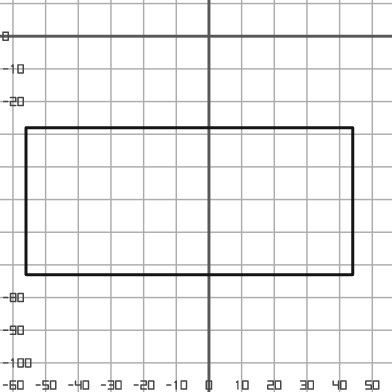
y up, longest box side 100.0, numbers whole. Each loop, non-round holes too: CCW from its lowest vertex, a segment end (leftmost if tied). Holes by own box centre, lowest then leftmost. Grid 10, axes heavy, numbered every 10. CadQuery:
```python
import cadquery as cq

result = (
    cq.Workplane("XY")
    .moveTo(-56.0, -73.0)
    .lineTo(44.0, -73.0)
    .lineTo(44.0, -28.0)
    .lineTo(-56.0, -28.0)
    .close()
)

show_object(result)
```